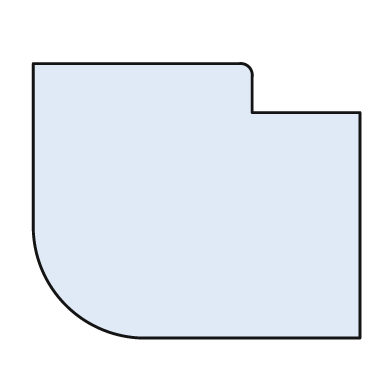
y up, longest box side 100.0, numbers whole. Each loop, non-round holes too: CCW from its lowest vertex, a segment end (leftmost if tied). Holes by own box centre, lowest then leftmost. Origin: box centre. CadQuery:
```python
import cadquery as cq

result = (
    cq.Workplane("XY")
    .moveTo(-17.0, -42.0)
    .lineTo(50.0, -42.0)
    .lineTo(50.0, 27.0)
    .lineTo(17.0, 27.0)
    .lineTo(17.0, 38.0)
    .threePointArc((16.0, 41.0), (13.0, 42.0))
    .lineTo(-50.0, 42.0)
    .lineTo(-50.0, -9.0)
    .threePointArc((-40.0, -32.0), (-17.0, -42.0))
    .close()
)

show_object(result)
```